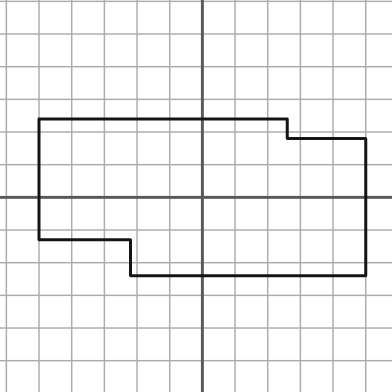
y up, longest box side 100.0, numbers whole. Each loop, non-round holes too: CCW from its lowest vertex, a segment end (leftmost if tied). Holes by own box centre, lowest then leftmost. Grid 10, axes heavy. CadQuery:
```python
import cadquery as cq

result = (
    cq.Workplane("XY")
    .moveTo(-22.0, -24.0)
    .lineTo(50.0, -24.0)
    .lineTo(50.0, 18.0)
    .lineTo(26.0, 18.0)
    .lineTo(26.0, 24.0)
    .lineTo(-50.0, 24.0)
    .lineTo(-50.0, -13.0)
    .lineTo(-22.0, -13.0)
    .close()
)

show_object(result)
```